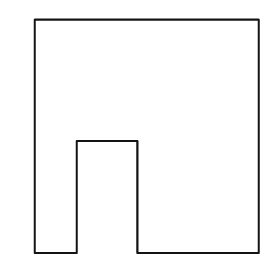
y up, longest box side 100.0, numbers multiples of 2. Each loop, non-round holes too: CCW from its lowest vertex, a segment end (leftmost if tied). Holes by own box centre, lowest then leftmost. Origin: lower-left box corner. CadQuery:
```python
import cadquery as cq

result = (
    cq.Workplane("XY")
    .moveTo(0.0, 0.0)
    .lineTo(18.0, 0.0)
    .lineTo(18.0, 48.0)
    .lineTo(44.0, 48.0)
    .lineTo(44.0, 0.0)
    .lineTo(96.0, 0.0)
    .lineTo(96.0, 100.0)
    .lineTo(0.0, 100.0)
    .close()
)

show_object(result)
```